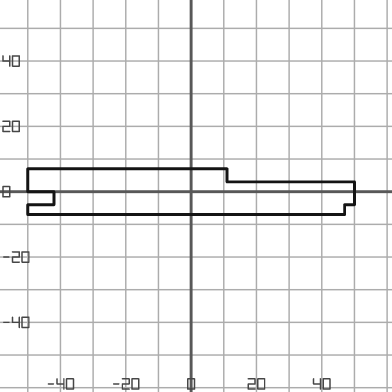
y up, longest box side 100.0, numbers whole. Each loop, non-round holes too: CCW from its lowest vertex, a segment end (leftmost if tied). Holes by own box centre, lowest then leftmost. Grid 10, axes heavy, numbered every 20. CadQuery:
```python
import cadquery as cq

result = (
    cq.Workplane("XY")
    .moveTo(-50.0, -7.0)
    .lineTo(47.0, -7.0)
    .lineTo(47.0, -4.0)
    .lineTo(50.0, -4.0)
    .lineTo(50.0, 3.0)
    .lineTo(11.0, 3.0)
    .lineTo(11.0, 7.0)
    .lineTo(-50.0, 7.0)
    .lineTo(-50.0, 0.0)
    .lineTo(-42.0, 0.0)
    .lineTo(-42.0, -4.0)
    .lineTo(-50.0, -4.0)
    .close()
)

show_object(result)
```